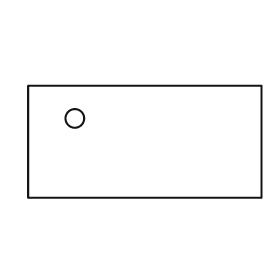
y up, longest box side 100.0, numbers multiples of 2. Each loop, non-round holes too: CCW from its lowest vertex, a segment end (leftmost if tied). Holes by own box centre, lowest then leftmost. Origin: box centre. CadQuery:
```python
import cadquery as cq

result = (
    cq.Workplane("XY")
    .moveTo(-50.0, -24.0)
    .lineTo(50.0, -24.0)
    .lineTo(50.0, 24.0)
    .lineTo(-50.0, 24.0)
    .close()
    .moveTo(-30.0, 10.0)
    .circle(4.0)
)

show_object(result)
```